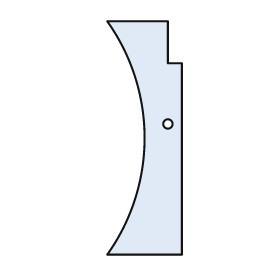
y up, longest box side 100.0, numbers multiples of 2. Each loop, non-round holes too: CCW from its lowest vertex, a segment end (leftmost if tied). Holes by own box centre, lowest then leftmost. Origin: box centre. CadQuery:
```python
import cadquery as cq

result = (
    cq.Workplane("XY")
    .moveTo(-16.0, -50.0)
    .lineTo(16.0, -50.0)
    .lineTo(16.0, 32.0)
    .lineTo(10.0, 32.0)
    .lineTo(10.0, 50.0)
    .lineTo(-16.0, 50.0)
    .threePointArc((0.0, 0.0), (-16.0, -50.0))
    .close()
    .moveTo(10.0, 6.0)
    .circle(2.0)
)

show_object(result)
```